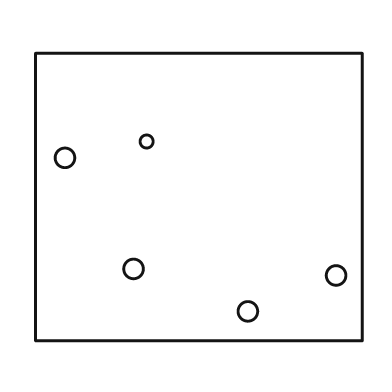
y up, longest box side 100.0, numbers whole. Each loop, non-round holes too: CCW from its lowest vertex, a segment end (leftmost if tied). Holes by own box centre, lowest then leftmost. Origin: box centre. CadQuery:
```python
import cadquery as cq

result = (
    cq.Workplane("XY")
    .moveTo(-50.0, -44.0)
    .lineTo(50.0, -44.0)
    .lineTo(50.0, 44.0)
    .lineTo(-50.0, 44.0)
    .close()
    .moveTo(15.0, -35.0)
    .circle(3.0)
    .moveTo(42.0, -24.0)
    .circle(3.0)
    .moveTo(-20.0, -22.0)
    .circle(3.0)
    .moveTo(-41.0, 12.0)
    .circle(3.0)
    .moveTo(-16.0, 17.0)
    .circle(2.0)
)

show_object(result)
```